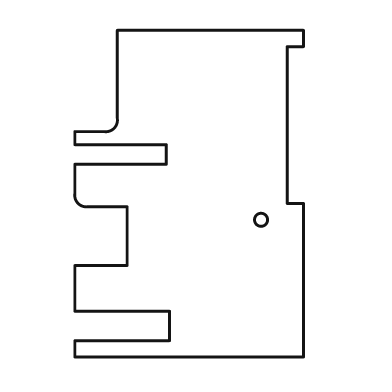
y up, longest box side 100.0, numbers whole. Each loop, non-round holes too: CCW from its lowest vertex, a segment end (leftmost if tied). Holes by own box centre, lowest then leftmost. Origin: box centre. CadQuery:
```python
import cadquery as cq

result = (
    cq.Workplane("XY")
    .moveTo(-35.0, -50.0)
    .lineTo(35.0, -50.0)
    .lineTo(35.0, -3.0)
    .lineTo(30.0, -3.0)
    .lineTo(30.0, 45.0)
    .lineTo(35.0, 45.0)
    .lineTo(35.0, 50.0)
    .lineTo(-22.0, 50.0)
    .lineTo(-22.0, 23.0)
    .threePointArc((-23.0, 20.0), (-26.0, 19.0))
    .lineTo(-35.0, 19.0)
    .lineTo(-35.0, 15.0)
    .lineTo(-7.0, 15.0)
    .lineTo(-7.0, 9.0)
    .lineTo(-35.0, 9.0)
    .lineTo(-35.0, 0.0)
    .threePointArc((-34.0, -3.0), (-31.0, -4.0))
    .lineTo(-19.0, -4.0)
    .lineTo(-19.0, -22.0)
    .lineTo(-35.0, -22.0)
    .lineTo(-35.0, -36.0)
    .lineTo(-6.0, -36.0)
    .lineTo(-6.0, -45.0)
    .lineTo(-35.0, -45.0)
    .close()
    .moveTo(22.0, -8.0)
    .circle(2.0)
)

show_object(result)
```